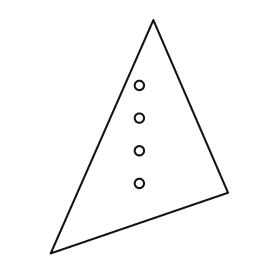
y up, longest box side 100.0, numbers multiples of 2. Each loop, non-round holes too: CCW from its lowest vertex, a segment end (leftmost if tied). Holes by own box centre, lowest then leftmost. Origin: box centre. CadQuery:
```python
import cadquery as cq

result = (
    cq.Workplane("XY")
    .moveTo(-38.0, -50.0)
    .lineTo(38.0, -24.0)
    .lineTo(6.0, 50.0)
    .close()
    .moveTo(0.0, -20.0)
    .circle(2.0)
    .moveTo(0.0, -6.0)
    .circle(2.0)
    .moveTo(0.0, 8.0)
    .circle(2.0)
    .moveTo(0.0, 22.0)
    .circle(2.0)
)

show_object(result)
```